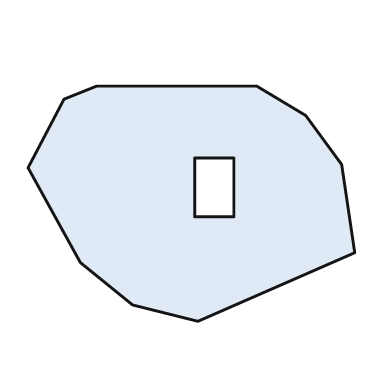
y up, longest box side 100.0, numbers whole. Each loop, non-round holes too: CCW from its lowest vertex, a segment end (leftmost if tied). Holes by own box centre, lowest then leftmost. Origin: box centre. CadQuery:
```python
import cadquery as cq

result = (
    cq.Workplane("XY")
    .moveTo(2.0, -36.0)
    .lineTo(50.0, -15.0)
    .lineTo(46.0, 12.0)
    .lineTo(35.0, 27.0)
    .lineTo(20.0, 36.0)
    .lineTo(-29.0, 36.0)
    .lineTo(-39.0, 32.0)
    .lineTo(-50.0, 11.0)
    .lineTo(-34.0, -18.0)
    .lineTo(-18.0, -31.0)
    .close()
    .moveTo(1.0, -4.0)
    .lineTo(13.0, -4.0)
    .lineTo(13.0, 14.0)
    .lineTo(1.0, 14.0)
    .close()
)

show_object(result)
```